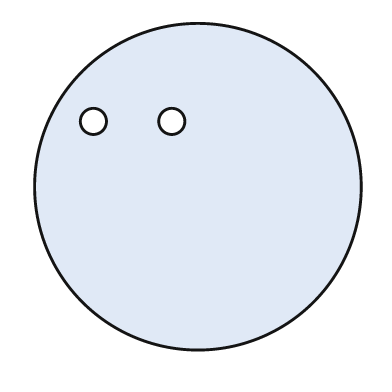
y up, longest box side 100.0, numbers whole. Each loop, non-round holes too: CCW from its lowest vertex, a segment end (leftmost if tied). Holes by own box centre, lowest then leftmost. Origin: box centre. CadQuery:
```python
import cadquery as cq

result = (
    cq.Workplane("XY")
    .moveTo(0.0, 0.0)
    .circle(50.0)
    .moveTo(-32.0, 20.0)
    .circle(4.0)
    .moveTo(-8.0, 20.0)
    .circle(4.0)
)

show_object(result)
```